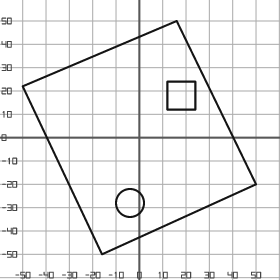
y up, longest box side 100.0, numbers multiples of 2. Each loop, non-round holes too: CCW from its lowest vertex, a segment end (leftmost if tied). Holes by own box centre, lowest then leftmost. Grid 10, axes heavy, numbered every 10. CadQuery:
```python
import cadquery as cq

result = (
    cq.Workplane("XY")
    .moveTo(-16.0, -50.0)
    .lineTo(50.0, -20.0)
    .lineTo(16.0, 50.0)
    .lineTo(-50.0, 22.0)
    .close()
    .moveTo(-4.0, -28.0)
    .circle(6.0)
    .moveTo(12.0, 12.0)
    .lineTo(24.0, 12.0)
    .lineTo(24.0, 24.0)
    .lineTo(12.0, 24.0)
    .close()
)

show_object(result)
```